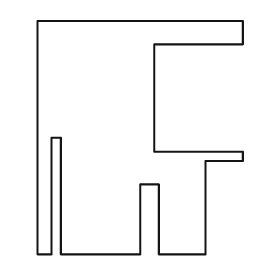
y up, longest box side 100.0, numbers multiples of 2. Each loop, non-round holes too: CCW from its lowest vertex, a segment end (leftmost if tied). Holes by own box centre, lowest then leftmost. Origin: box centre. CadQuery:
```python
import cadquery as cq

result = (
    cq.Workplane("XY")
    .moveTo(-44.0, -50.0)
    .lineTo(-38.0, -50.0)
    .lineTo(-38.0, 0.0)
    .lineTo(-34.0, 0.0)
    .lineTo(-34.0, -50.0)
    .lineTo(0.0, -50.0)
    .lineTo(0.0, -20.0)
    .lineTo(8.0, -20.0)
    .lineTo(8.0, -50.0)
    .lineTo(28.0, -50.0)
    .lineTo(28.0, -10.0)
    .lineTo(44.0, -10.0)
    .lineTo(44.0, -6.0)
    .lineTo(6.0, -6.0)
    .lineTo(6.0, 40.0)
    .lineTo(44.0, 40.0)
    .lineTo(44.0, 50.0)
    .lineTo(-44.0, 50.0)
    .close()
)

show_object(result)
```